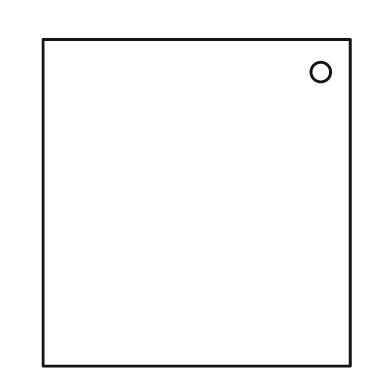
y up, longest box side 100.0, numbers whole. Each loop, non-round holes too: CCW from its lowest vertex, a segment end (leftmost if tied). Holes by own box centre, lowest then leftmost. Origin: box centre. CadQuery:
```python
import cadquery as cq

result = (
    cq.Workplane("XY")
    .moveTo(-47.0, -50.0)
    .lineTo(47.0, -50.0)
    .lineTo(47.0, 50.0)
    .lineTo(-47.0, 50.0)
    .close()
    .moveTo(38.0, 40.0)
    .circle(3.0)
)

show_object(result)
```